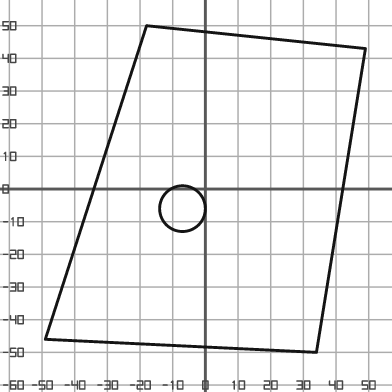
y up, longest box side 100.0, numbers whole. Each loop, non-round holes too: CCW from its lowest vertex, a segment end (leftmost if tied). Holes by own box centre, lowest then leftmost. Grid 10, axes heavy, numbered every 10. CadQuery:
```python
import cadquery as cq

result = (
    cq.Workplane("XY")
    .moveTo(34.0, -50.0)
    .lineTo(49.0, 43.0)
    .lineTo(-18.0, 50.0)
    .lineTo(-49.0, -46.0)
    .close()
    .moveTo(-7.0, -6.0)
    .circle(7.0)
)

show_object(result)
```